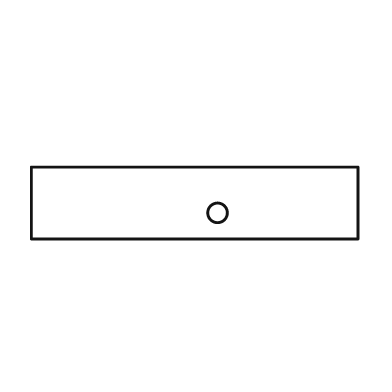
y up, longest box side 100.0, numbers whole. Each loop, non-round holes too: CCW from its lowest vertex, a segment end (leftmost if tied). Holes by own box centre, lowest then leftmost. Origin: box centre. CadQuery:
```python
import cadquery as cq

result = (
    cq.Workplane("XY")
    .moveTo(-50.0, -11.0)
    .lineTo(50.0, -11.0)
    .lineTo(50.0, 11.0)
    .lineTo(-50.0, 11.0)
    .close()
    .moveTo(7.0, -3.0)
    .circle(3.0)
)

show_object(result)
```